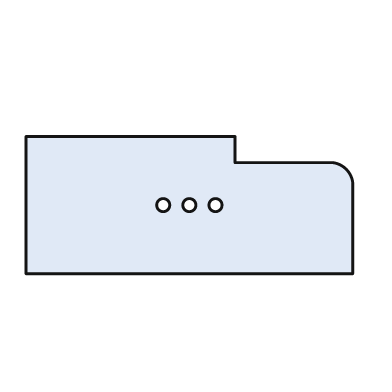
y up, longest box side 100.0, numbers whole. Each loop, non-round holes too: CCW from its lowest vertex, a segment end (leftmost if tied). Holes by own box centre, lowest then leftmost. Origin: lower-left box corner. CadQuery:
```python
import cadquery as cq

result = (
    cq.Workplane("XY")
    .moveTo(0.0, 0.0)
    .lineTo(100.0, 0.0)
    .lineTo(100.0, 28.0)
    .threePointArc((98.0, 32.0), (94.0, 34.0))
    .lineTo(64.0, 34.0)
    .lineTo(64.0, 42.0)
    .lineTo(0.0, 42.0)
    .close()
    .moveTo(42.0, 21.0)
    .circle(2.0)
    .moveTo(50.0, 21.0)
    .circle(2.0)
    .moveTo(58.0, 21.0)
    .circle(2.0)
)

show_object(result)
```